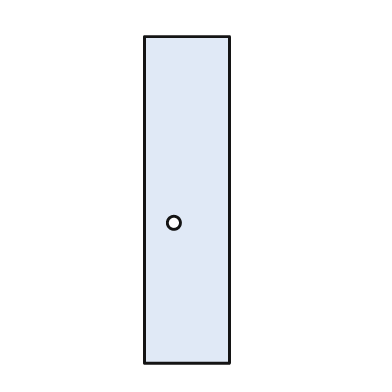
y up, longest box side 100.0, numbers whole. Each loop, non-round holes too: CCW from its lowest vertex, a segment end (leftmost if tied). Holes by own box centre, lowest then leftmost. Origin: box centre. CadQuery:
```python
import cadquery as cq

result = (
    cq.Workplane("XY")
    .moveTo(-13.0, -50.0)
    .lineTo(13.0, -50.0)
    .lineTo(13.0, 50.0)
    .lineTo(-13.0, 50.0)
    .close()
    .moveTo(-4.0, -7.0)
    .circle(2.0)
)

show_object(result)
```